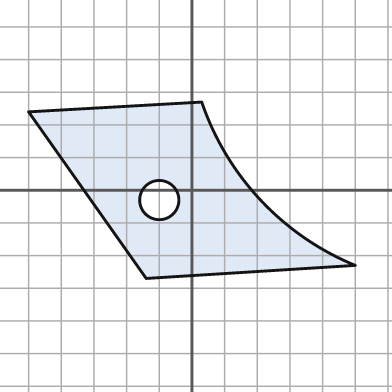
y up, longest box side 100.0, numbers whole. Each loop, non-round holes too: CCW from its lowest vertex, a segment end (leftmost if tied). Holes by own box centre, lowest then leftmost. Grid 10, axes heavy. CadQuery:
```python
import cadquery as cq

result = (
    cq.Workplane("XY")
    .moveTo(-14.0, -27.0)
    .lineTo(50.0, -23.0)
    .threePointArc((21.0, -3.0), (3.0, 27.0))
    .lineTo(-50.0, 24.0)
    .close()
    .moveTo(-10.0, -3.0)
    .circle(6.0)
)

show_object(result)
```